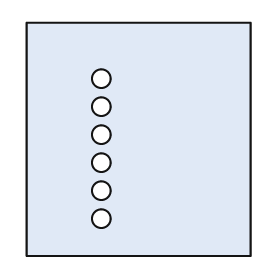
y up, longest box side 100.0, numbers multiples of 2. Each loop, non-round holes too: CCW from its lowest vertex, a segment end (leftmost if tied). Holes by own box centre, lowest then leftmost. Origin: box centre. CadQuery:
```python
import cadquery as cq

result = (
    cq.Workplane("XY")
    .moveTo(-48.0, -50.0)
    .lineTo(48.0, -50.0)
    .lineTo(48.0, 50.0)
    .lineTo(-48.0, 50.0)
    .close()
    .moveTo(-16.0, -34.0)
    .circle(4.0)
    .moveTo(-16.0, -22.0)
    .circle(4.0)
    .moveTo(-16.0, -10.0)
    .circle(4.0)
    .moveTo(-16.0, 2.0)
    .circle(4.0)
    .moveTo(-16.0, 14.0)
    .circle(4.0)
    .moveTo(-16.0, 26.0)
    .circle(4.0)
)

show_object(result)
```